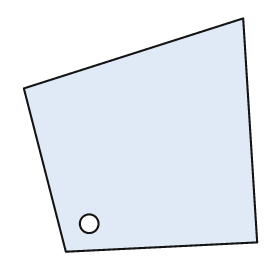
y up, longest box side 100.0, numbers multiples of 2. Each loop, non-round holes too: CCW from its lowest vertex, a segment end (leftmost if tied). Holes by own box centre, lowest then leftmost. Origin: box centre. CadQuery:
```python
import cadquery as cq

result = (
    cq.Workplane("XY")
    .moveTo(-32.0, -50.0)
    .lineTo(50.0, -46.0)
    .lineTo(44.0, 50.0)
    .lineTo(-50.0, 20.0)
    .close()
    .moveTo(-22.0, -38.0)
    .circle(4.0)
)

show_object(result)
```